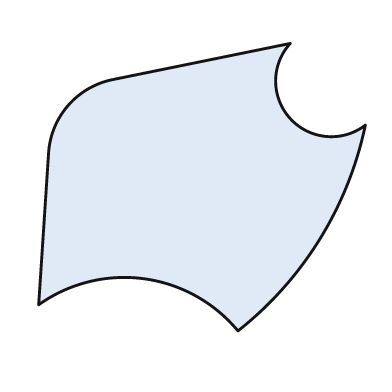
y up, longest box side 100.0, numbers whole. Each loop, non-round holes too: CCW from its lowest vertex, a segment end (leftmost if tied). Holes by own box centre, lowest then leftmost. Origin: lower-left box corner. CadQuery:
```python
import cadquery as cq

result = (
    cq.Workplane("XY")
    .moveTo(61.0, 0.0)
    .threePointArc((86.0, 28.0), (100.0, 63.0))
    .threePointArc((77.0, 65.0), (77.0, 88.0))
    .lineTo(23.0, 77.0)
    .threePointArc((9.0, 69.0), (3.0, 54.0))
    .lineTo(0.0, 8.0)
    .threePointArc((32.0, 16.0), (61.0, 0.0))
    .close()
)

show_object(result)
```